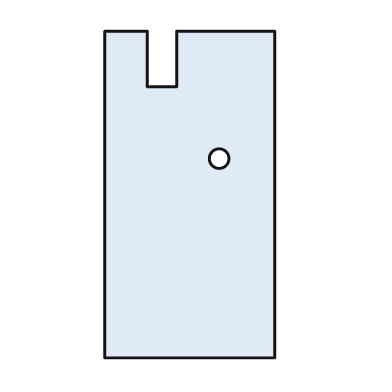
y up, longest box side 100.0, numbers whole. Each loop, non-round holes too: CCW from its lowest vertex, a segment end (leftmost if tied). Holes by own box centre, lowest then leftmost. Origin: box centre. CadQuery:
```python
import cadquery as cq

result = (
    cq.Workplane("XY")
    .moveTo(-26.0, -50.0)
    .lineTo(26.0, -50.0)
    .lineTo(26.0, 50.0)
    .lineTo(-4.0, 50.0)
    .lineTo(-4.0, 33.0)
    .lineTo(-13.0, 33.0)
    .lineTo(-13.0, 50.0)
    .lineTo(-26.0, 50.0)
    .close()
    .moveTo(9.0, 11.0)
    .circle(3.0)
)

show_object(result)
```